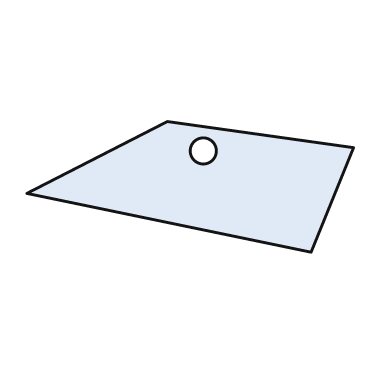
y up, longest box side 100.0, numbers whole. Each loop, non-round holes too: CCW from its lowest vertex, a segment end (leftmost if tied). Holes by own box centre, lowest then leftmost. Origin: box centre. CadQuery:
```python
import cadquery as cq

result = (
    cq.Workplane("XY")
    .moveTo(37.0, -20.0)
    .lineTo(50.0, 12.0)
    .lineTo(-7.0, 20.0)
    .lineTo(-50.0, -2.0)
    .close()
    .moveTo(4.0, 11.0)
    .circle(4.0)
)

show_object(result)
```